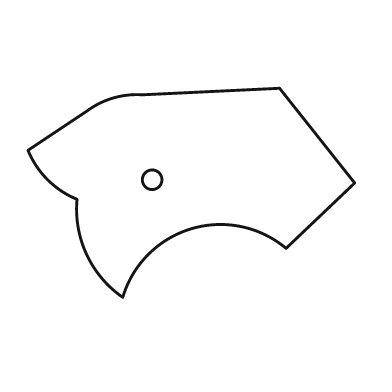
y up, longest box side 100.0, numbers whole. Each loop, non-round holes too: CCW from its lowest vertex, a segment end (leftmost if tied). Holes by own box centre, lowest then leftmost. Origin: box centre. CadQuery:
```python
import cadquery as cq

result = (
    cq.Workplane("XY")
    .moveTo(-21.0, -32.0)
    .threePointArc((0.0, -11.0), (29.0, -17.0))
    .lineTo(50.0, 3.0)
    .lineTo(27.0, 32.0)
    .lineTo(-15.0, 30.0)
    .threePointArc((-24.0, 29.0), (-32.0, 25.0))
    .lineTo(-50.0, 13.0)
    .threePointArc((-44.0, 4.0), (-35.0, -2.0))
    .threePointArc((-32.0, -19.0), (-21.0, -32.0))
    .close()
    .moveTo(-12.0, 4.0)
    .circle(3.0)
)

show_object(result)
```